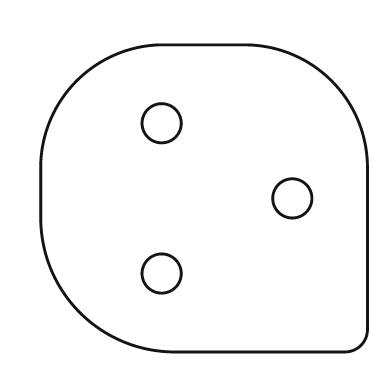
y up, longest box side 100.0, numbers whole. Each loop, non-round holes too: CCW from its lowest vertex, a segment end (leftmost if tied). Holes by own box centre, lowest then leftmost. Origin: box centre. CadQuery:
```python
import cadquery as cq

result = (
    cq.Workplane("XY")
    .moveTo(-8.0, -47.0)
    .lineTo(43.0, -47.0)
    .threePointArc((48.0, -45.0), (50.0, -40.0))
    .lineTo(50.0, 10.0)
    .threePointArc((39.0, 36.0), (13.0, 47.0))
    .lineTo(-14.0, 47.0)
    .threePointArc((-39.0, 36.0), (-50.0, 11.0))
    .lineTo(-50.0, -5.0)
    .threePointArc((-38.0, -35.0), (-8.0, -47.0))
    .close()
    .moveTo(-13.0, -23.0)
    .circle(6.0)
    .moveTo(27.0, 0.0)
    .circle(6.0)
    .moveTo(-13.0, 23.0)
    .circle(6.0)
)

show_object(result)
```